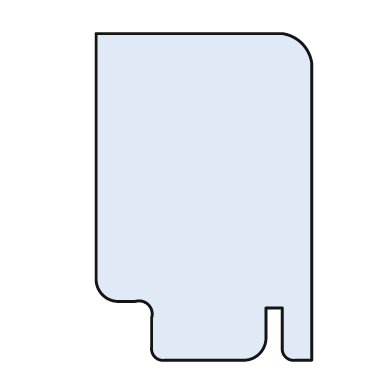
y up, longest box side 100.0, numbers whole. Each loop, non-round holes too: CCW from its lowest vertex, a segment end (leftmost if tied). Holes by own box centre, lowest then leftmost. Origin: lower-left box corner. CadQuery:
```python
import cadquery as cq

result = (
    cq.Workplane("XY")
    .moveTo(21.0, 0.0)
    .lineTo(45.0, 0.0)
    .threePointArc((50.0, 2.0), (52.0, 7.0))
    .lineTo(52.0, 16.0)
    .lineTo(57.0, 16.0)
    .lineTo(57.0, 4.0)
    .threePointArc((58.0, 1.0), (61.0, 0.0))
    .lineTo(66.0, 0.0)
    .lineTo(66.0, 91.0)
    .threePointArc((63.0, 97.0), (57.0, 100.0))
    .lineTo(0.0, 100.0)
    .lineTo(0.0, 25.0)
    .threePointArc((2.0, 20.0), (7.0, 18.0))
    .lineTo(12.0, 18.0)
    .threePointArc((16.0, 17.0), (17.0, 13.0))
    .lineTo(17.0, 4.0)
    .threePointArc((18.0, 1.0), (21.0, 0.0))
    .close()
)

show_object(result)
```